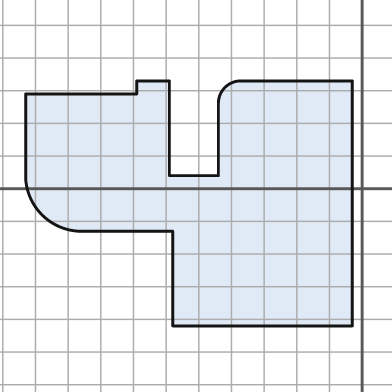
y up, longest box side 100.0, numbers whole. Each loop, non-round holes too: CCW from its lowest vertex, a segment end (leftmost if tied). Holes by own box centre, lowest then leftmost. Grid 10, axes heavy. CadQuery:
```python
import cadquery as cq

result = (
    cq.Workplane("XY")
    .moveTo(-58.0, -42.0)
    .lineTo(-3.0, -42.0)
    .lineTo(-3.0, 33.0)
    .lineTo(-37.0, 33.0)
    .threePointArc((-42.0, 31.0), (-44.0, 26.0))
    .lineTo(-44.0, 4.0)
    .lineTo(-59.0, 4.0)
    .lineTo(-59.0, 33.0)
    .lineTo(-69.0, 33.0)
    .lineTo(-69.0, 29.0)
    .lineTo(-103.0, 29.0)
    .lineTo(-103.0, 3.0)
    .threePointArc((-98.0, -8.0), (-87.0, -13.0))
    .lineTo(-58.0, -13.0)
    .close()
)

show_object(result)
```